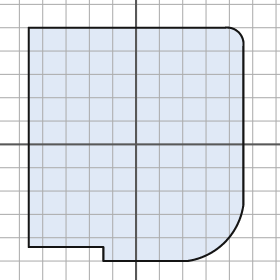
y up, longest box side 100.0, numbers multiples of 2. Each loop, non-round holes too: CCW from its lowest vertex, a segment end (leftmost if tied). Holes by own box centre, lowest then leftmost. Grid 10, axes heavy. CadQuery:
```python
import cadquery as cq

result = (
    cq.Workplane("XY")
    .moveTo(-14.0, -50.0)
    .lineTo(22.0, -50.0)
    .threePointArc((38.0, -42.0), (46.0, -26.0))
    .lineTo(46.0, 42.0)
    .threePointArc((44.0, 48.0), (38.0, 50.0))
    .lineTo(-46.0, 50.0)
    .lineTo(-46.0, -44.0)
    .lineTo(-14.0, -44.0)
    .close()
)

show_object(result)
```